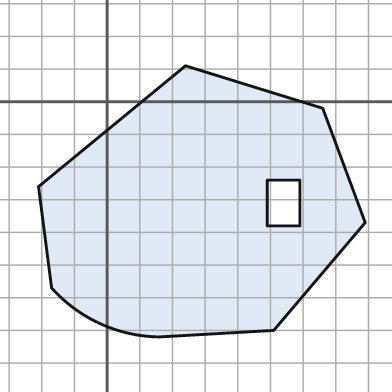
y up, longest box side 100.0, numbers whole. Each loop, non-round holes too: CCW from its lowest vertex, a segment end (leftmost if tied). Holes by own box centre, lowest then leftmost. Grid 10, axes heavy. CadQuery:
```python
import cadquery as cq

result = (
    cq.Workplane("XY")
    .moveTo(16.0, -72.0)
    .lineTo(51.0, -70.0)
    .lineTo(79.0, -37.0)
    .lineTo(66.0, -2.0)
    .lineTo(24.0, 11.0)
    .lineTo(-21.0, -26.0)
    .lineTo(-17.0, -57.0)
    .threePointArc((-2.0, -68.0), (16.0, -72.0))
    .close()
    .moveTo(49.0, -38.0)
    .lineTo(59.0, -38.0)
    .lineTo(59.0, -24.0)
    .lineTo(49.0, -24.0)
    .close()
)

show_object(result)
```